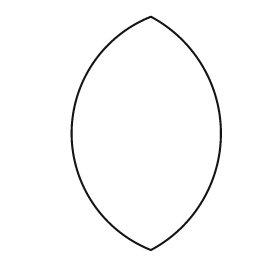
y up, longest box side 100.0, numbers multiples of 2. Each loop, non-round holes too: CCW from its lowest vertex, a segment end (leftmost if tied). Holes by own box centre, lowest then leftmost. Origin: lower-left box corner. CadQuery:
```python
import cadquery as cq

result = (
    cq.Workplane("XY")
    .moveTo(34.0, 0.0)
    .threePointArc((64.0, 50.0), (34.0, 100.0))
    .threePointArc((0.0, 50.0), (34.0, 0.0))
    .close()
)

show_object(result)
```